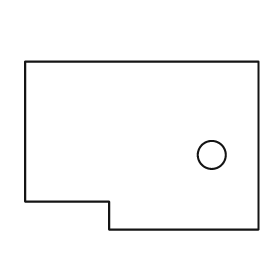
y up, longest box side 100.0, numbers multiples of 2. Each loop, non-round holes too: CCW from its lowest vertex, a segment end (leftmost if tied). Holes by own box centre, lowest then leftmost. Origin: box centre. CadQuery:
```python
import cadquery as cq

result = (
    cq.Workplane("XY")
    .moveTo(-14.0, -36.0)
    .lineTo(50.0, -36.0)
    .lineTo(50.0, 36.0)
    .lineTo(-50.0, 36.0)
    .lineTo(-50.0, -24.0)
    .lineTo(-14.0, -24.0)
    .close()
    .moveTo(30.0, -4.0)
    .circle(6.0)
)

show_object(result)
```